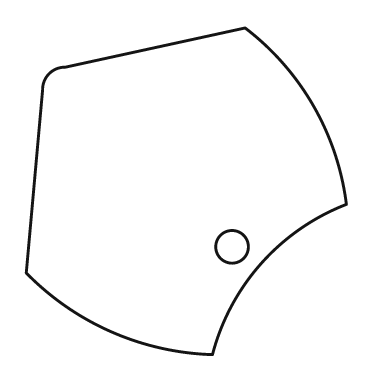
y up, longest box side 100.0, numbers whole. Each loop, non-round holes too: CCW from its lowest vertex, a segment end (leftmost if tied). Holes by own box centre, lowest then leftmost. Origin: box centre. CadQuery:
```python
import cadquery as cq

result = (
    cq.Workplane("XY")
    .moveTo(8.0, -50.0)
    .threePointArc((23.0, -22.0), (49.0, -4.0))
    .threePointArc((39.0, 26.0), (18.0, 50.0))
    .lineTo(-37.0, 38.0)
    .threePointArc((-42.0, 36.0), (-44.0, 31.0))
    .lineTo(-49.0, -25.0)
    .threePointArc((-23.0, -43.0), (8.0, -50.0))
    .close()
    .moveTo(14.0, -17.0)
    .circle(5.0)
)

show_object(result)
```